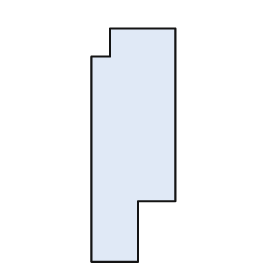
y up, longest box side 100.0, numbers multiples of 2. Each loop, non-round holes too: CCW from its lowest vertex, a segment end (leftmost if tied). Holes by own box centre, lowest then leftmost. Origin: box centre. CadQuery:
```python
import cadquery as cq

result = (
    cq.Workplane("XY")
    .moveTo(-18.0, -50.0)
    .lineTo(2.0, -50.0)
    .lineTo(2.0, -24.0)
    .lineTo(18.0, -24.0)
    .lineTo(18.0, 50.0)
    .lineTo(-10.0, 50.0)
    .lineTo(-10.0, 38.0)
    .lineTo(-18.0, 38.0)
    .close()
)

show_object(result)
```